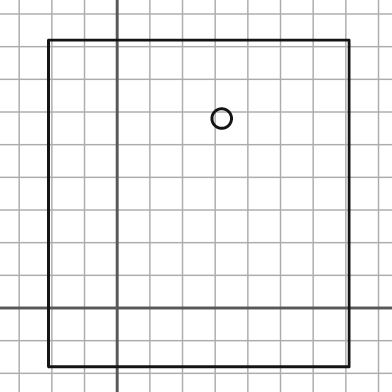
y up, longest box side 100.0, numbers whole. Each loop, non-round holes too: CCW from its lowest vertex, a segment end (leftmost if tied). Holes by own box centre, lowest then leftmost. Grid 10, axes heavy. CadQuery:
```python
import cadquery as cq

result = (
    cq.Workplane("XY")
    .moveTo(-21.0, -18.0)
    .lineTo(71.0, -18.0)
    .lineTo(71.0, 82.0)
    .lineTo(-21.0, 82.0)
    .close()
    .moveTo(32.0, 58.0)
    .circle(3.0)
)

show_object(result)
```